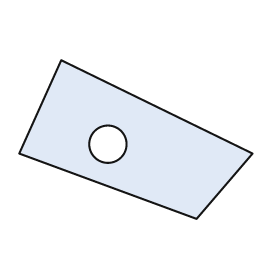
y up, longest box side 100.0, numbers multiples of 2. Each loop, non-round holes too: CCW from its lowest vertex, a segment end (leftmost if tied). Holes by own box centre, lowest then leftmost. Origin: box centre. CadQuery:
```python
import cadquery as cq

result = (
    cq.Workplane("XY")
    .moveTo(26.0, -34.0)
    .lineTo(50.0, -6.0)
    .lineTo(-32.0, 34.0)
    .lineTo(-50.0, -6.0)
    .close()
    .moveTo(-12.0, -2.0)
    .circle(8.0)
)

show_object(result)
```